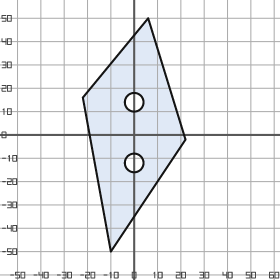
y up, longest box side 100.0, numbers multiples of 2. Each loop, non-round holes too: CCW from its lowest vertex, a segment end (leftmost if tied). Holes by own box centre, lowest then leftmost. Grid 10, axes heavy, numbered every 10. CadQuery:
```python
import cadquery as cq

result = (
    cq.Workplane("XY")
    .moveTo(-10.0, -50.0)
    .lineTo(22.0, -2.0)
    .lineTo(6.0, 50.0)
    .lineTo(-22.0, 16.0)
    .close()
    .moveTo(0.0, -12.0)
    .circle(4.0)
    .moveTo(0.0, 14.0)
    .circle(4.0)
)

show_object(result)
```